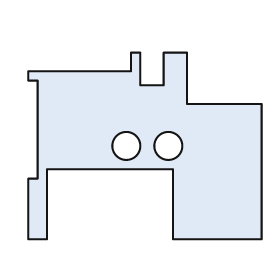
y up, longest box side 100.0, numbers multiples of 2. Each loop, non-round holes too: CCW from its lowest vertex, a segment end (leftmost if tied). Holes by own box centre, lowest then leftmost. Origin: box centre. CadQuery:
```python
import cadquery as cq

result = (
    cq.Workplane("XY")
    .moveTo(-50.0, -40.0)
    .lineTo(-42.0, -40.0)
    .lineTo(-42.0, -10.0)
    .lineTo(12.0, -10.0)
    .lineTo(12.0, -40.0)
    .lineTo(50.0, -40.0)
    .lineTo(50.0, 18.0)
    .lineTo(18.0, 18.0)
    .lineTo(18.0, 40.0)
    .lineTo(8.0, 40.0)
    .lineTo(8.0, 26.0)
    .lineTo(-2.0, 26.0)
    .lineTo(-2.0, 40.0)
    .lineTo(-6.0, 40.0)
    .lineTo(-6.0, 32.0)
    .lineTo(-50.0, 32.0)
    .lineTo(-50.0, 28.0)
    .lineTo(-46.0, 28.0)
    .lineTo(-46.0, -14.0)
    .lineTo(-50.0, -14.0)
    .close()
    .moveTo(-8.0, 0.0)
    .circle(6.0)
    .moveTo(10.0, 0.0)
    .circle(6.0)
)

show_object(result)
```